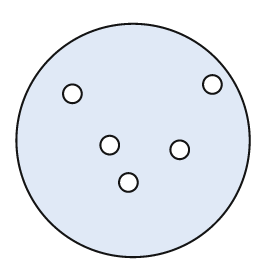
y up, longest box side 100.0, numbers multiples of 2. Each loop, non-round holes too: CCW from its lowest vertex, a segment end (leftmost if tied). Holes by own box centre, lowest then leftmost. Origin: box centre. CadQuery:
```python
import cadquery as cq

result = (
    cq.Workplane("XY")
    .moveTo(0.0, 0.0)
    .circle(50.0)
    .moveTo(-2.0, -18.0)
    .circle(4.0)
    .moveTo(20.0, -4.0)
    .circle(4.0)
    .moveTo(-10.0, -2.0)
    .circle(4.0)
    .moveTo(-26.0, 20.0)
    .circle(4.0)
    .moveTo(34.0, 24.0)
    .circle(4.0)
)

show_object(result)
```